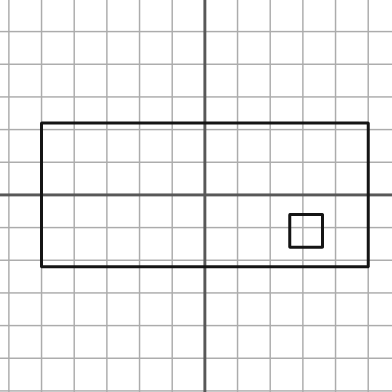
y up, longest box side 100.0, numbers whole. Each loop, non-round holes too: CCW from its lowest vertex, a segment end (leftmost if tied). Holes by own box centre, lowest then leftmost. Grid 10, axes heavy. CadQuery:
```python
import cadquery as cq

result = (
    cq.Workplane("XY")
    .moveTo(-50.0, -22.0)
    .lineTo(50.0, -22.0)
    .lineTo(50.0, 22.0)
    .lineTo(-50.0, 22.0)
    .close()
    .moveTo(26.0, -16.0)
    .lineTo(36.0, -16.0)
    .lineTo(36.0, -6.0)
    .lineTo(26.0, -6.0)
    .close()
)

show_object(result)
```